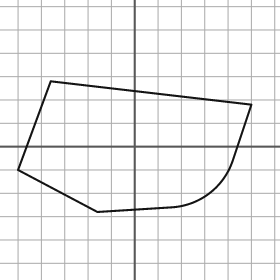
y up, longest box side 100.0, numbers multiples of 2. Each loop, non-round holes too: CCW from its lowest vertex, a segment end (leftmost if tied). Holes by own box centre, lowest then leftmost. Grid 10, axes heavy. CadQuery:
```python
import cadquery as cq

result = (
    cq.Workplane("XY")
    .moveTo(-16.0, -28.0)
    .lineTo(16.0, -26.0)
    .threePointArc((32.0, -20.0), (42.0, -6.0))
    .lineTo(50.0, 18.0)
    .lineTo(-36.0, 28.0)
    .lineTo(-50.0, -10.0)
    .close()
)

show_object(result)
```